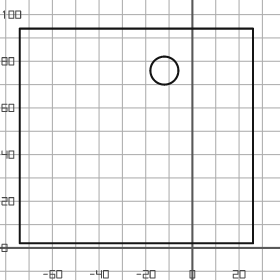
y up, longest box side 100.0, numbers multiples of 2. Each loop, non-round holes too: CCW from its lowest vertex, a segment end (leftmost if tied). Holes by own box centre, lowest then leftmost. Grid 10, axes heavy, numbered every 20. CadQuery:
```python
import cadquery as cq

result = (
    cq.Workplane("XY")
    .moveTo(-74.0, 2.0)
    .lineTo(26.0, 2.0)
    .lineTo(26.0, 94.0)
    .lineTo(-74.0, 94.0)
    .close()
    .moveTo(-12.0, 76.0)
    .circle(6.0)
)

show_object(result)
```